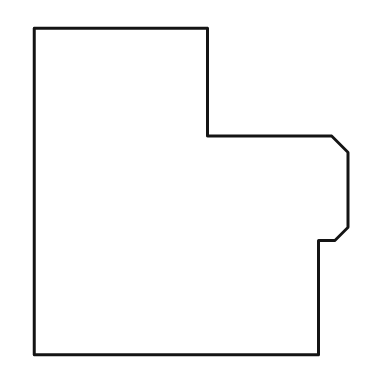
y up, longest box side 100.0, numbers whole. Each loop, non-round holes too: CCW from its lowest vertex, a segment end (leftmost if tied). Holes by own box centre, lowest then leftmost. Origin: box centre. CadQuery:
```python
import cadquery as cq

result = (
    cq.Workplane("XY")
    .moveTo(-48.0, -50.0)
    .lineTo(39.0, -50.0)
    .lineTo(39.0, -15.0)
    .lineTo(44.0, -15.0)
    .lineTo(48.0, -11.0)
    .lineTo(48.0, 12.0)
    .lineTo(43.0, 17.0)
    .lineTo(5.0, 17.0)
    .lineTo(5.0, 50.0)
    .lineTo(-48.0, 50.0)
    .close()
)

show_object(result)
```